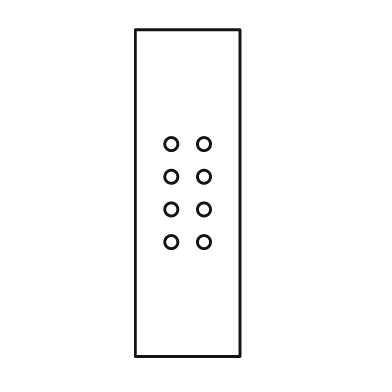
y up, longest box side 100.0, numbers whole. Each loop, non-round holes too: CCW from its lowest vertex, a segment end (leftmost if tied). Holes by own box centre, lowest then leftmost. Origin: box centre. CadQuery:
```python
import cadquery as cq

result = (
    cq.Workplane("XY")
    .moveTo(-16.0, -50.0)
    .lineTo(16.0, -50.0)
    .lineTo(16.0, 50.0)
    .lineTo(-16.0, 50.0)
    .close()
    .moveTo(-5.0, -15.0)
    .circle(2.0)
    .moveTo(5.0, -15.0)
    .circle(2.0)
    .moveTo(-5.0, -5.0)
    .circle(2.0)
    .moveTo(5.0, -5.0)
    .circle(2.0)
    .moveTo(-5.0, 5.0)
    .circle(2.0)
    .moveTo(5.0, 5.0)
    .circle(2.0)
    .moveTo(-5.0, 15.0)
    .circle(2.0)
    .moveTo(5.0, 15.0)
    .circle(2.0)
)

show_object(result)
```